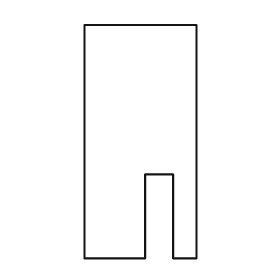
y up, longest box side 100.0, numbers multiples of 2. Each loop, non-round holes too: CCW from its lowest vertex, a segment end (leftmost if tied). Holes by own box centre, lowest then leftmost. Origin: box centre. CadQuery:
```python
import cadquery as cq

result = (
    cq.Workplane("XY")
    .moveTo(-24.0, -50.0)
    .lineTo(2.0, -50.0)
    .lineTo(2.0, -14.0)
    .lineTo(14.0, -14.0)
    .lineTo(14.0, -50.0)
    .lineTo(24.0, -50.0)
    .lineTo(24.0, 50.0)
    .lineTo(-24.0, 50.0)
    .close()
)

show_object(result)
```